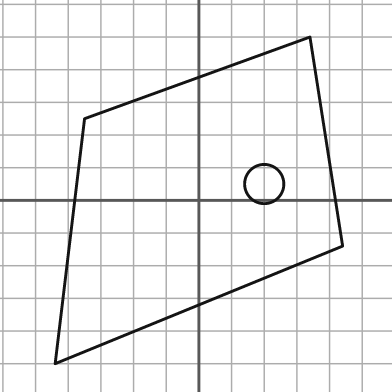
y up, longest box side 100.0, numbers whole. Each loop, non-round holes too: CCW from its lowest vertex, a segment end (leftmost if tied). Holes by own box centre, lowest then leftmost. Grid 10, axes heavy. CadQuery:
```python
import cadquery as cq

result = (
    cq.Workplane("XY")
    .moveTo(-44.0, -50.0)
    .lineTo(44.0, -14.0)
    .lineTo(34.0, 50.0)
    .lineTo(-35.0, 25.0)
    .close()
    .moveTo(20.0, 5.0)
    .circle(6.0)
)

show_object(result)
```